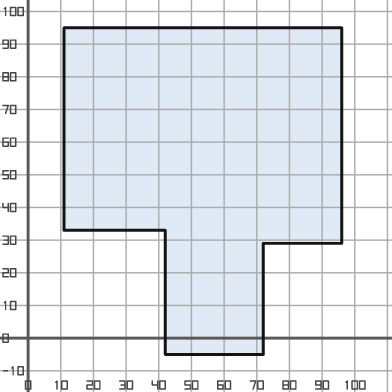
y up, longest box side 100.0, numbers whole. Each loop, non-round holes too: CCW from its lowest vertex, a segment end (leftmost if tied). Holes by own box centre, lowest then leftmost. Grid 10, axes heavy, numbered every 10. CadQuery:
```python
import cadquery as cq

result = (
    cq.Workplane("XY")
    .moveTo(42.0, -5.0)
    .lineTo(72.0, -5.0)
    .lineTo(72.0, 29.0)
    .lineTo(96.0, 29.0)
    .lineTo(96.0, 95.0)
    .lineTo(11.0, 95.0)
    .lineTo(11.0, 33.0)
    .lineTo(42.0, 33.0)
    .close()
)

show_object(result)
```